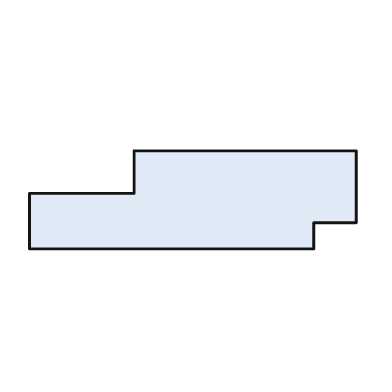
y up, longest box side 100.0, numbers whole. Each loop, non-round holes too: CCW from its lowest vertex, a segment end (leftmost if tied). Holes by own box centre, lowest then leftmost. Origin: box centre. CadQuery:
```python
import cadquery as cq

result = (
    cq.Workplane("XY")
    .moveTo(-50.0, -15.0)
    .lineTo(37.0, -15.0)
    .lineTo(37.0, -7.0)
    .lineTo(50.0, -7.0)
    .lineTo(50.0, 15.0)
    .lineTo(-18.0, 15.0)
    .lineTo(-18.0, 2.0)
    .lineTo(-50.0, 2.0)
    .close()
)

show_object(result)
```